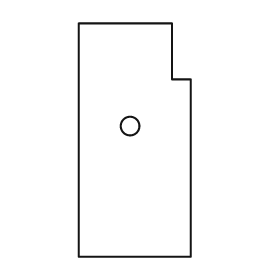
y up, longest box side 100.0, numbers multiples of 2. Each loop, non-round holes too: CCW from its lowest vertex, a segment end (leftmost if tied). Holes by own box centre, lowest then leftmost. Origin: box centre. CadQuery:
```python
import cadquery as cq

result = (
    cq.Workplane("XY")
    .moveTo(-24.0, -50.0)
    .lineTo(24.0, -50.0)
    .lineTo(24.0, 26.0)
    .lineTo(16.0, 26.0)
    .lineTo(16.0, 50.0)
    .lineTo(-24.0, 50.0)
    .close()
    .moveTo(-2.0, 6.0)
    .circle(4.0)
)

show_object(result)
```